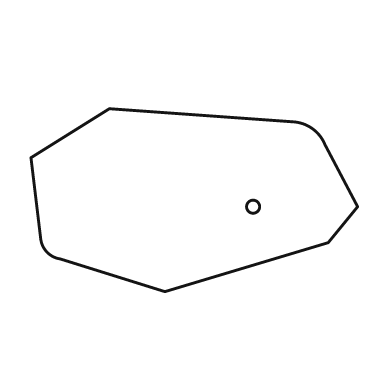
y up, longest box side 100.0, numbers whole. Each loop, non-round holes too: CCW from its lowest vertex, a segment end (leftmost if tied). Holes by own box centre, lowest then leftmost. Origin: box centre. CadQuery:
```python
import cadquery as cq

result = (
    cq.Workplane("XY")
    .moveTo(-9.0, -28.0)
    .lineTo(41.0, -13.0)
    .lineTo(50.0, -2.0)
    .lineTo(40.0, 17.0)
    .threePointArc((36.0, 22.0), (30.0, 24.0))
    .lineTo(-26.0, 28.0)
    .lineTo(-50.0, 13.0)
    .lineTo(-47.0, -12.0)
    .threePointArc((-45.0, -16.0), (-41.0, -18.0))
    .close()
    .moveTo(18.0, -2.0)
    .circle(2.0)
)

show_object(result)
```